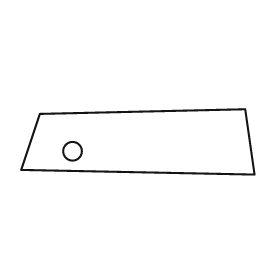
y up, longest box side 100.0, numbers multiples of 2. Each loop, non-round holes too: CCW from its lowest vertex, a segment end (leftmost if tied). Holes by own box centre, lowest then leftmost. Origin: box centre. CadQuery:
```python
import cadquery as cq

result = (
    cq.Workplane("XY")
    .moveTo(50.0, -14.0)
    .lineTo(46.0, 14.0)
    .lineTo(-42.0, 12.0)
    .lineTo(-50.0, -12.0)
    .close()
    .moveTo(-28.0, -4.0)
    .circle(4.0)
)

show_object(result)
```